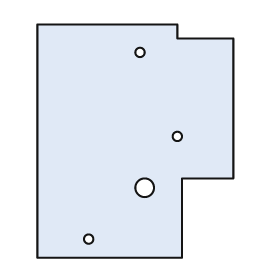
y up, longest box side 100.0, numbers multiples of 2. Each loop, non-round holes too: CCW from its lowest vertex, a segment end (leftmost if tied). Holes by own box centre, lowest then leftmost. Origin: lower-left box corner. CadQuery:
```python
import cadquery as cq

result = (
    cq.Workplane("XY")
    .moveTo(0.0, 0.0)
    .lineTo(62.0, 0.0)
    .lineTo(62.0, 34.0)
    .lineTo(84.0, 34.0)
    .lineTo(84.0, 94.0)
    .lineTo(60.0, 94.0)
    .lineTo(60.0, 100.0)
    .lineTo(0.0, 100.0)
    .close()
    .moveTo(22.0, 8.0)
    .circle(2.0)
    .moveTo(46.0, 30.0)
    .circle(4.0)
    .moveTo(60.0, 52.0)
    .circle(2.0)
    .moveTo(44.0, 88.0)
    .circle(2.0)
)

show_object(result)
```